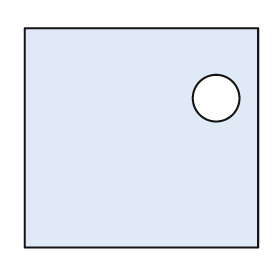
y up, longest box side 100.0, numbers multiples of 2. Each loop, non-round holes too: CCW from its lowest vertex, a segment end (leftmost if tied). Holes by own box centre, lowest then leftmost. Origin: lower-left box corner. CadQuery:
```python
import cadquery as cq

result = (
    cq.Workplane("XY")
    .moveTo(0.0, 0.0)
    .lineTo(100.0, 0.0)
    .lineTo(100.0, 94.0)
    .lineTo(0.0, 94.0)
    .close()
    .moveTo(82.0, 64.0)
    .circle(10.0)
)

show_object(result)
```